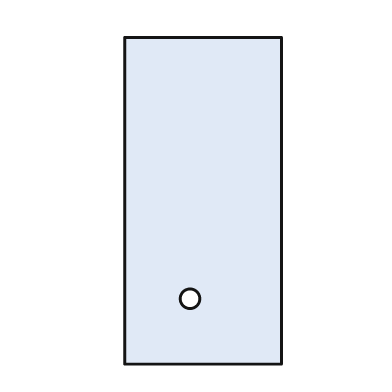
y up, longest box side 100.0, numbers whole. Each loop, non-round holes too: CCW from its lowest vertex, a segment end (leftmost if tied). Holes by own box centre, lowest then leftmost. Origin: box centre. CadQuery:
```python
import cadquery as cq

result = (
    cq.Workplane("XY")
    .moveTo(-24.0, -50.0)
    .lineTo(24.0, -50.0)
    .lineTo(24.0, 50.0)
    .lineTo(-24.0, 50.0)
    .close()
    .moveTo(-4.0, -30.0)
    .circle(3.0)
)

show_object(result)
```